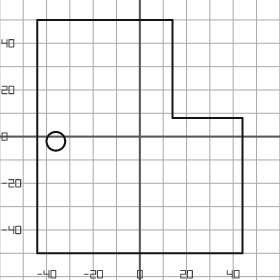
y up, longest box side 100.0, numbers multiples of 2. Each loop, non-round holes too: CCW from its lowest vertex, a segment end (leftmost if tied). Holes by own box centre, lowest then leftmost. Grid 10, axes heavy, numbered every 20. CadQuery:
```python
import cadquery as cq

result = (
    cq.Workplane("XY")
    .moveTo(-44.0, -50.0)
    .lineTo(44.0, -50.0)
    .lineTo(44.0, 8.0)
    .lineTo(14.0, 8.0)
    .lineTo(14.0, 50.0)
    .lineTo(-44.0, 50.0)
    .close()
    .moveTo(-36.0, -2.0)
    .circle(4.0)
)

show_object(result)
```